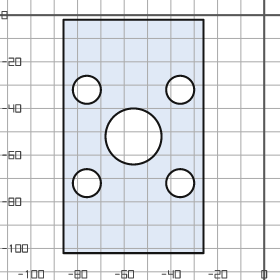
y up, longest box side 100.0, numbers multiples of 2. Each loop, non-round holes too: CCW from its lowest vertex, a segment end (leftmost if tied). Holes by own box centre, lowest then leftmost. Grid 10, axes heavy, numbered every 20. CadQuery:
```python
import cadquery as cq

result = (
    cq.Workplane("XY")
    .moveTo(-86.0, -102.0)
    .lineTo(-26.0, -102.0)
    .lineTo(-26.0, -2.0)
    .lineTo(-86.0, -2.0)
    .close()
    .moveTo(-76.0, -72.0)
    .circle(6.0)
    .moveTo(-36.0, -72.0)
    .circle(6.0)
    .moveTo(-56.0, -52.0)
    .circle(12.0)
    .moveTo(-76.0, -32.0)
    .circle(6.0)
    .moveTo(-36.0, -32.0)
    .circle(6.0)
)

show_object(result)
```